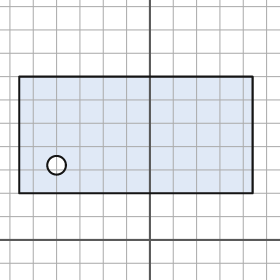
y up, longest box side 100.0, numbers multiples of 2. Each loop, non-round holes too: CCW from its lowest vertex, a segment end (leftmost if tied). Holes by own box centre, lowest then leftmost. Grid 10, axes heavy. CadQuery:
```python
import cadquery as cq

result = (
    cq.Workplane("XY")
    .moveTo(-56.0, 20.0)
    .lineTo(44.0, 20.0)
    .lineTo(44.0, 70.0)
    .lineTo(-56.0, 70.0)
    .close()
    .moveTo(-40.0, 32.0)
    .circle(4.0)
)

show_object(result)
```